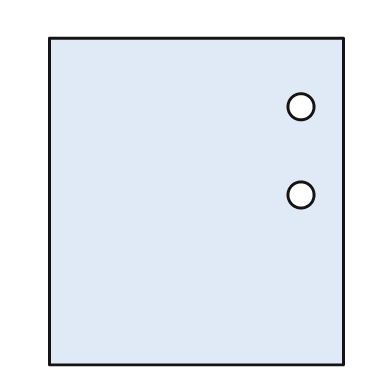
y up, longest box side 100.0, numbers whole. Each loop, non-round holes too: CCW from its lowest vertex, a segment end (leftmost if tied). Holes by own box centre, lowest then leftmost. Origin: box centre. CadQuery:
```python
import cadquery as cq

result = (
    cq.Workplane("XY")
    .moveTo(-45.0, -50.0)
    .lineTo(45.0, -50.0)
    .lineTo(45.0, 50.0)
    .lineTo(-45.0, 50.0)
    .close()
    .moveTo(32.0, 2.0)
    .circle(4.0)
    .moveTo(32.0, 29.0)
    .circle(4.0)
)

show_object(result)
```